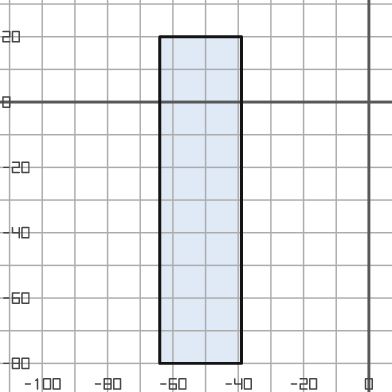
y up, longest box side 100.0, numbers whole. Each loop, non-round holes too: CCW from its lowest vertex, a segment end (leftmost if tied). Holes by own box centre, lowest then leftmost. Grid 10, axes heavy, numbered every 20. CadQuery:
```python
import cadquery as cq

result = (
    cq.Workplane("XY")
    .moveTo(-64.0, -80.0)
    .lineTo(-39.0, -80.0)
    .lineTo(-39.0, 20.0)
    .lineTo(-64.0, 20.0)
    .close()
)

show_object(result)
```